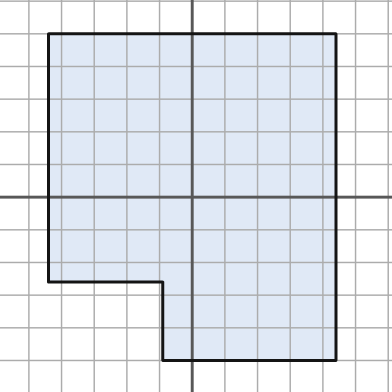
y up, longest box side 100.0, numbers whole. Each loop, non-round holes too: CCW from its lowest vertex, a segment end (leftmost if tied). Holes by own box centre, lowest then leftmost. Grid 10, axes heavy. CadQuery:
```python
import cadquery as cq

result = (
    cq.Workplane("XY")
    .moveTo(-9.0, -50.0)
    .lineTo(44.0, -50.0)
    .lineTo(44.0, 50.0)
    .lineTo(-44.0, 50.0)
    .lineTo(-44.0, -26.0)
    .lineTo(-9.0, -26.0)
    .close()
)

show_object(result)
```